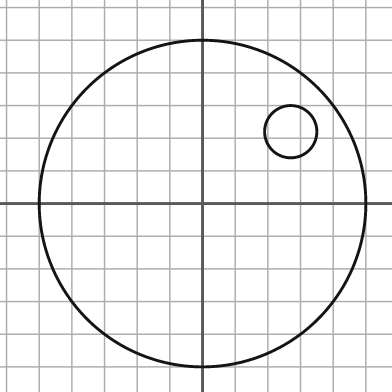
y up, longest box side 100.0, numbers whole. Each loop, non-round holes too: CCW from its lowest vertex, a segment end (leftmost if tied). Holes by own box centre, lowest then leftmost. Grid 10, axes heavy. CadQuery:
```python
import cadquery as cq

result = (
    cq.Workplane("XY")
    .moveTo(0.0, 0.0)
    .circle(50.0)
    .moveTo(27.0, 22.0)
    .circle(8.0)
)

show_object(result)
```